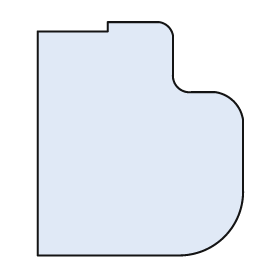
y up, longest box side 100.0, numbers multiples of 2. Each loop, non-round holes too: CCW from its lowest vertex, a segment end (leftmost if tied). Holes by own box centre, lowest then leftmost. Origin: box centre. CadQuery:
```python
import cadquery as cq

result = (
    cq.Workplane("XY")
    .moveTo(-44.0, -50.0)
    .lineTo(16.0, -50.0)
    .threePointArc((36.0, -42.0), (44.0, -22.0))
    .lineTo(44.0, 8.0)
    .threePointArc((40.0, 16.0), (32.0, 20.0))
    .lineTo(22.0, 20.0)
    .threePointArc((16.0, 22.0), (14.0, 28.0))
    .lineTo(14.0, 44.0)
    .threePointArc((12.0, 48.0), (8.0, 50.0))
    .lineTo(-14.0, 50.0)
    .lineTo(-14.0, 46.0)
    .lineTo(-44.0, 46.0)
    .close()
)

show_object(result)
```